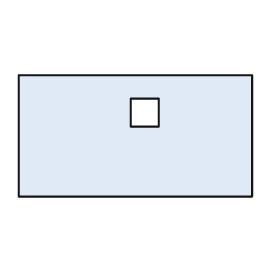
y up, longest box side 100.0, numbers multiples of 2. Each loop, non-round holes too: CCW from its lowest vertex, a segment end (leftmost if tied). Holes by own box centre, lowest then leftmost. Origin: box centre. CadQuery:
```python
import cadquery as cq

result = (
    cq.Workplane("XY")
    .moveTo(-50.0, -26.0)
    .lineTo(50.0, -26.0)
    .lineTo(50.0, 26.0)
    .lineTo(-50.0, 26.0)
    .close()
    .moveTo(-2.0, 4.0)
    .lineTo(10.0, 4.0)
    .lineTo(10.0, 16.0)
    .lineTo(-2.0, 16.0)
    .close()
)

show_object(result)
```